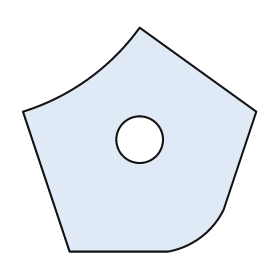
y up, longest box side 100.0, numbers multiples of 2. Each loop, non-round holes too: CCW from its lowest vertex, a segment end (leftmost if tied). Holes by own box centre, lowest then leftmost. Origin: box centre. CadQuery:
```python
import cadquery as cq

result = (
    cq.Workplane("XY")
    .moveTo(-30.0, -48.0)
    .lineTo(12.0, -48.0)
    .threePointArc((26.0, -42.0), (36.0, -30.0))
    .lineTo(50.0, 12.0)
    .lineTo(0.0, 48.0)
    .threePointArc((-22.0, 26.0), (-50.0, 12.0))
    .close()
    .moveTo(0.0, 0.0)
    .circle(10.0)
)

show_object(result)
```